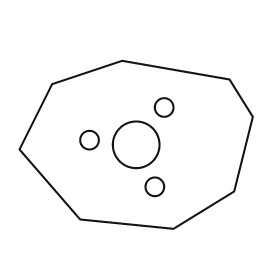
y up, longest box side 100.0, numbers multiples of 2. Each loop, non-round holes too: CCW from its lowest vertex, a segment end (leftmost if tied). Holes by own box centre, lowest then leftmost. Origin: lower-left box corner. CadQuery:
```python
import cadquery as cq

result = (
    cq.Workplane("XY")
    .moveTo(66.0, 0.0)
    .lineTo(92.0, 16.0)
    .lineTo(100.0, 48.0)
    .lineTo(90.0, 64.0)
    .lineTo(44.0, 72.0)
    .lineTo(14.0, 62.0)
    .lineTo(0.0, 34.0)
    .lineTo(26.0, 4.0)
    .close()
    .moveTo(58.0, 18.0)
    .circle(4.0)
    .moveTo(50.0, 36.0)
    .circle(10.0)
    .moveTo(30.0, 38.0)
    .circle(4.0)
    .moveTo(62.0, 52.0)
    .circle(4.0)
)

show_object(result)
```